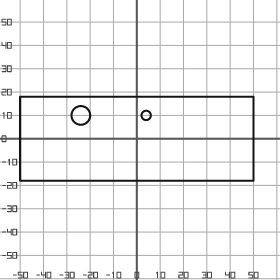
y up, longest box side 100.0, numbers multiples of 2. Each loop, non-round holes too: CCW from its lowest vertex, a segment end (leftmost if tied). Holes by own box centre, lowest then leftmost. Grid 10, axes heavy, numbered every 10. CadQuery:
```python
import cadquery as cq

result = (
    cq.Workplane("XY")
    .moveTo(-50.0, -18.0)
    .lineTo(50.0, -18.0)
    .lineTo(50.0, 18.0)
    .lineTo(-50.0, 18.0)
    .close()
    .moveTo(-24.0, 10.0)
    .circle(4.0)
    .moveTo(4.0, 10.0)
    .circle(2.0)
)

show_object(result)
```